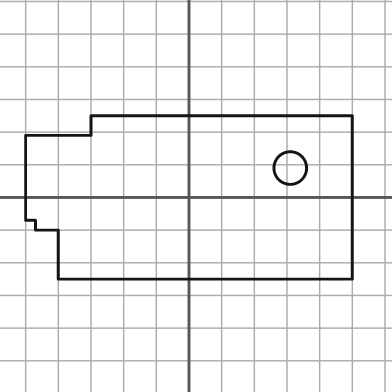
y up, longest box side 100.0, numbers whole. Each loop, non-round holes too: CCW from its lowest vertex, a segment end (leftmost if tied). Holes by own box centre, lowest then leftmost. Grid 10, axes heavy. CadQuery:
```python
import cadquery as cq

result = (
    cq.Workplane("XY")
    .moveTo(-40.0, -25.0)
    .lineTo(50.0, -25.0)
    .lineTo(50.0, 25.0)
    .lineTo(-30.0, 25.0)
    .lineTo(-30.0, 19.0)
    .lineTo(-50.0, 19.0)
    .lineTo(-50.0, -7.0)
    .lineTo(-47.0, -7.0)
    .lineTo(-47.0, -10.0)
    .lineTo(-40.0, -10.0)
    .close()
    .moveTo(31.0, 9.0)
    .circle(5.0)
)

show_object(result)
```